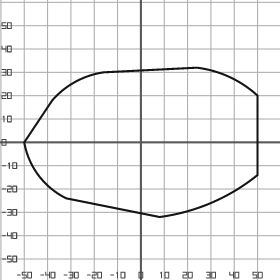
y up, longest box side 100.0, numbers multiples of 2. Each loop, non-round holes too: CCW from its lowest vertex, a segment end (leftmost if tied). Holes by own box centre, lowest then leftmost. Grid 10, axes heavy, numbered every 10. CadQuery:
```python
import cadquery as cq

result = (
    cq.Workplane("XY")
    .moveTo(8.0, -32.0)
    .threePointArc((30.0, -26.0), (50.0, -14.0))
    .lineTo(50.0, 20.0)
    .threePointArc((38.0, 28.0), (24.0, 32.0))
    .lineTo(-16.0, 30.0)
    .threePointArc((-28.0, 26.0), (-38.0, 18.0))
    .lineTo(-50.0, 0.0)
    .threePointArc((-44.0, -14.0), (-32.0, -24.0))
    .close()
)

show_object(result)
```